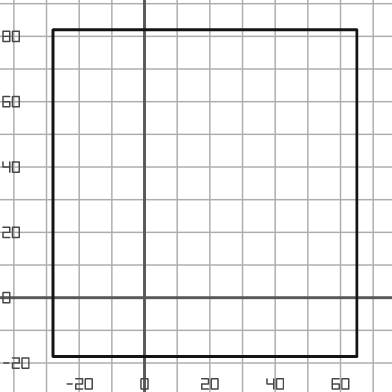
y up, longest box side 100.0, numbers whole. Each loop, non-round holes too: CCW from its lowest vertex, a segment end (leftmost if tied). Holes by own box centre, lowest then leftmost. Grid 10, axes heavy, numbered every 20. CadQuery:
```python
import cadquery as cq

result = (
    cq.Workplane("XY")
    .moveTo(-28.0, -18.0)
    .lineTo(65.0, -18.0)
    .lineTo(65.0, 82.0)
    .lineTo(-28.0, 82.0)
    .close()
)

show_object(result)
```